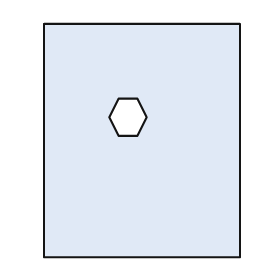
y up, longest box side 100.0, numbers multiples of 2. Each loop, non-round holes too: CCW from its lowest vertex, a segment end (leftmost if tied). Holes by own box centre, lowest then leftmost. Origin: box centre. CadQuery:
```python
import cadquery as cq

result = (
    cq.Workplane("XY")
    .moveTo(-42.0, -50.0)
    .lineTo(42.0, -50.0)
    .lineTo(42.0, 50.0)
    .lineTo(-42.0, 50.0)
    .close()
    .moveTo(-10.0, 2.0)
    .lineTo(-2.0, 2.0)
    .lineTo(2.0, 10.0)
    .lineTo(-2.0, 18.0)
    .lineTo(-10.0, 18.0)
    .lineTo(-14.0, 10.0)
    .close()
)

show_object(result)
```